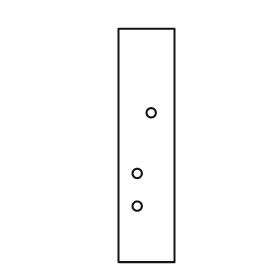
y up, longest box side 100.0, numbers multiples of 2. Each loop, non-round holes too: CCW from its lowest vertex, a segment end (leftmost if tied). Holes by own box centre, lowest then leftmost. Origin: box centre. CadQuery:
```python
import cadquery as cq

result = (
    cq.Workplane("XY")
    .moveTo(-12.0, -50.0)
    .lineTo(12.0, -50.0)
    .lineTo(12.0, 50.0)
    .lineTo(-12.0, 50.0)
    .close()
    .moveTo(-4.0, -26.0)
    .circle(2.0)
    .moveTo(-4.0, -12.0)
    .circle(2.0)
    .moveTo(2.0, 14.0)
    .circle(2.0)
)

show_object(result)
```